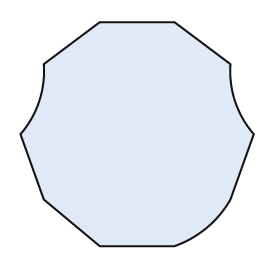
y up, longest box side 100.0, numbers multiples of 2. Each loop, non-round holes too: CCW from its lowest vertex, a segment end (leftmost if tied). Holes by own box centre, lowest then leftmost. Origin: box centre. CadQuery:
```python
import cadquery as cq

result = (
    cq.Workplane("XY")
    .moveTo(-16.0, -48.0)
    .lineTo(16.0, -48.0)
    .threePointArc((30.0, -40.0), (40.0, -28.0))
    .lineTo(50.0, 0.0)
    .threePointArc((42.0, 14.0), (40.0, 30.0))
    .lineTo(16.0, 48.0)
    .lineTo(-16.0, 48.0)
    .lineTo(-40.0, 30.0)
    .threePointArc((-42.0, 14.0), (-50.0, 0.0))
    .lineTo(-40.0, -28.0)
    .close()
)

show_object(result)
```